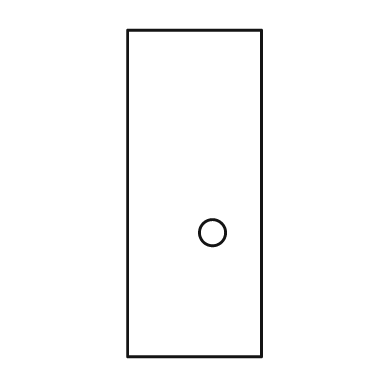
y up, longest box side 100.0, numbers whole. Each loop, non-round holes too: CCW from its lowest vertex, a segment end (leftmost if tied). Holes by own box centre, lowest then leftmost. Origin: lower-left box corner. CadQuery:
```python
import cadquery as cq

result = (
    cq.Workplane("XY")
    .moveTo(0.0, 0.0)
    .lineTo(41.0, 0.0)
    .lineTo(41.0, 100.0)
    .lineTo(0.0, 100.0)
    .close()
    .moveTo(26.0, 38.0)
    .circle(4.0)
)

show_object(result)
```